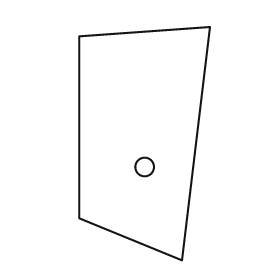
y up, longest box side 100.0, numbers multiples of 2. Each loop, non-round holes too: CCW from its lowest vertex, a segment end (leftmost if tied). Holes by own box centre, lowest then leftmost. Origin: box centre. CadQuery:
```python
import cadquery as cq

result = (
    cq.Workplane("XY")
    .moveTo(16.0, -50.0)
    .lineTo(28.0, 50.0)
    .lineTo(-28.0, 46.0)
    .lineTo(-28.0, -32.0)
    .close()
    .moveTo(0.0, -10.0)
    .circle(4.0)
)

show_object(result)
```